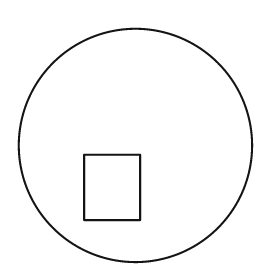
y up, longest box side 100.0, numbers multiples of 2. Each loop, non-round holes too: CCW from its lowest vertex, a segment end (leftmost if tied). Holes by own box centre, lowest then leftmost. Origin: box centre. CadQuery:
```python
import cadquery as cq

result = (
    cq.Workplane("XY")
    .moveTo(0.0, 0.0)
    .circle(50.0)
    .moveTo(-22.0, -32.0)
    .lineTo(2.0, -32.0)
    .lineTo(2.0, -4.0)
    .lineTo(-22.0, -4.0)
    .close()
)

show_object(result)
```